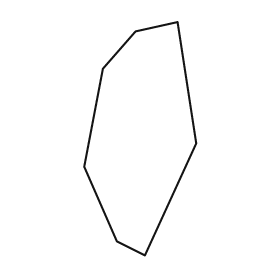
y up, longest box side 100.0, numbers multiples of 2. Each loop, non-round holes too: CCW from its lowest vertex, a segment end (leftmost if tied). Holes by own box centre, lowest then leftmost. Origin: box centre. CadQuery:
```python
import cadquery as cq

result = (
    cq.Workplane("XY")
    .moveTo(2.0, -50.0)
    .lineTo(24.0, -2.0)
    .lineTo(16.0, 50.0)
    .lineTo(-2.0, 46.0)
    .lineTo(-16.0, 30.0)
    .lineTo(-24.0, -12.0)
    .lineTo(-10.0, -44.0)
    .close()
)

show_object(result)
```